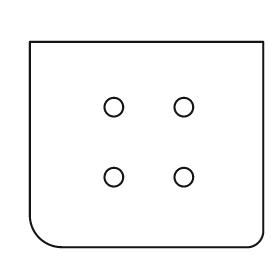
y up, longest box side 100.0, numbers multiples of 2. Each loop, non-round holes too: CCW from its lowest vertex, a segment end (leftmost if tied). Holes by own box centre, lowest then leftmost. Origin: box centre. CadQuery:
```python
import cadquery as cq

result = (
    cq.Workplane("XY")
    .moveTo(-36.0, -44.0)
    .lineTo(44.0, -44.0)
    .threePointArc((48.0, -42.0), (50.0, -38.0))
    .lineTo(50.0, 44.0)
    .lineTo(-50.0, 44.0)
    .lineTo(-50.0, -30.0)
    .threePointArc((-46.0, -40.0), (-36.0, -44.0))
    .close()
    .moveTo(-14.0, -14.0)
    .circle(4.0)
    .moveTo(16.0, -14.0)
    .circle(4.0)
    .moveTo(-14.0, 16.0)
    .circle(4.0)
    .moveTo(16.0, 16.0)
    .circle(4.0)
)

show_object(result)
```